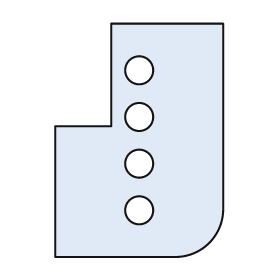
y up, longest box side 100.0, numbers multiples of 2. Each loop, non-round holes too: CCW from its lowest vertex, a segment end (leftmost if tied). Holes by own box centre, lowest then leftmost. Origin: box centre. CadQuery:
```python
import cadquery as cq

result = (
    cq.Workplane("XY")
    .moveTo(-36.0, -50.0)
    .lineTo(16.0, -50.0)
    .threePointArc((30.0, -44.0), (36.0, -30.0))
    .lineTo(36.0, 50.0)
    .lineTo(-12.0, 50.0)
    .lineTo(-12.0, 6.0)
    .lineTo(-36.0, 6.0)
    .close()
    .moveTo(0.0, -30.0)
    .circle(6.0)
    .moveTo(0.0, -10.0)
    .circle(6.0)
    .moveTo(0.0, 10.0)
    .circle(6.0)
    .moveTo(0.0, 30.0)
    .circle(6.0)
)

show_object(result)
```